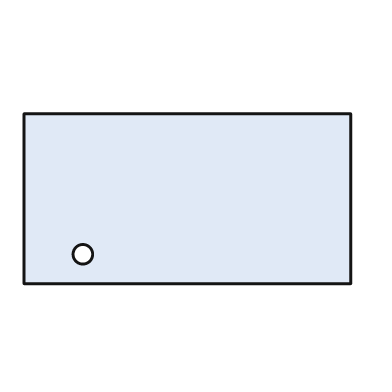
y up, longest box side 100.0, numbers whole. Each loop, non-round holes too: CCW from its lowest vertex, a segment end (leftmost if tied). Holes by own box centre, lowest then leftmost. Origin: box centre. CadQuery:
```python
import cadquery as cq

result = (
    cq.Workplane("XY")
    .moveTo(-50.0, -26.0)
    .lineTo(50.0, -26.0)
    .lineTo(50.0, 26.0)
    .lineTo(-50.0, 26.0)
    .close()
    .moveTo(-32.0, -17.0)
    .circle(3.0)
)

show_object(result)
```